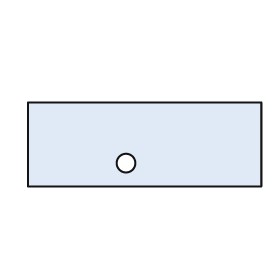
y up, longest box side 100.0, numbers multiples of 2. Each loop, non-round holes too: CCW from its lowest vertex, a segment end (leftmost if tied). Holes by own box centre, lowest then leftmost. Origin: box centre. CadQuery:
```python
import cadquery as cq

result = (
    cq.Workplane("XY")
    .moveTo(-50.0, -18.0)
    .lineTo(50.0, -18.0)
    .lineTo(50.0, 18.0)
    .lineTo(-50.0, 18.0)
    .close()
    .moveTo(-8.0, -8.0)
    .circle(4.0)
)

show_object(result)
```